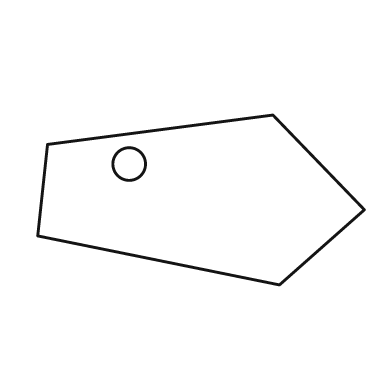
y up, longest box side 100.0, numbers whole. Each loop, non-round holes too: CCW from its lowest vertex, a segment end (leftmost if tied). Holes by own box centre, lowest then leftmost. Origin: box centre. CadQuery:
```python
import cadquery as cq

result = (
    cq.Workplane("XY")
    .moveTo(24.0, -26.0)
    .lineTo(50.0, -3.0)
    .lineTo(22.0, 26.0)
    .lineTo(-47.0, 17.0)
    .lineTo(-50.0, -11.0)
    .close()
    .moveTo(-22.0, 11.0)
    .circle(5.0)
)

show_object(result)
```